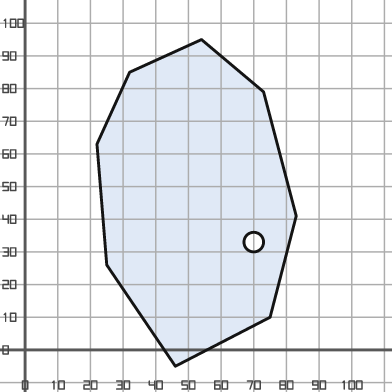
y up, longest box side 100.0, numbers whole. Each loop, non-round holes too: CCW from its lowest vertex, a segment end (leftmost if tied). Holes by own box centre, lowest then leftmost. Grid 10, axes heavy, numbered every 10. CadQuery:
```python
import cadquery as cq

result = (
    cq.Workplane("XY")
    .moveTo(46.0, -5.0)
    .lineTo(75.0, 10.0)
    .lineTo(83.0, 41.0)
    .lineTo(73.0, 79.0)
    .lineTo(54.0, 95.0)
    .lineTo(32.0, 85.0)
    .lineTo(22.0, 63.0)
    .lineTo(25.0, 26.0)
    .close()
    .moveTo(70.0, 33.0)
    .circle(3.0)
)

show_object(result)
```